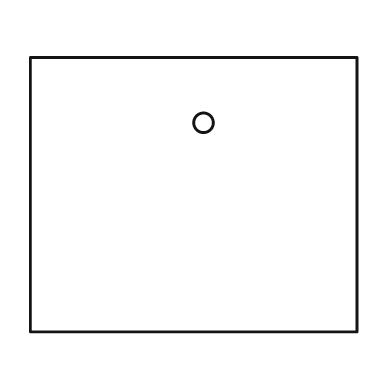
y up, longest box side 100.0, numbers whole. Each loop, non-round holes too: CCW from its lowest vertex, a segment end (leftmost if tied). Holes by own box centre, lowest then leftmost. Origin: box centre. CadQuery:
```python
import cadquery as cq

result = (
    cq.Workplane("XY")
    .moveTo(-50.0, -42.0)
    .lineTo(50.0, -42.0)
    .lineTo(50.0, 42.0)
    .lineTo(-50.0, 42.0)
    .close()
    .moveTo(3.0, 22.0)
    .circle(3.0)
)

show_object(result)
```